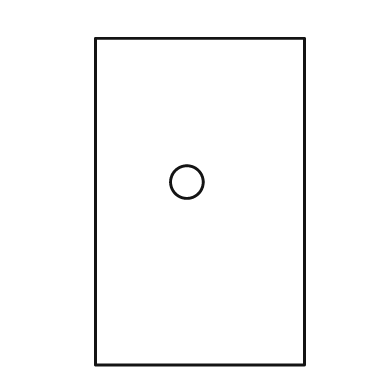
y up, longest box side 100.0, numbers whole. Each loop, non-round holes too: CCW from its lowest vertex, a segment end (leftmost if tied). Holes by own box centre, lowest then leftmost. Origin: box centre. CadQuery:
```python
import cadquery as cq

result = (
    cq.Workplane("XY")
    .moveTo(-32.0, -50.0)
    .lineTo(32.0, -50.0)
    .lineTo(32.0, 50.0)
    .lineTo(-32.0, 50.0)
    .close()
    .moveTo(-4.0, 6.0)
    .circle(5.0)
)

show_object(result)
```